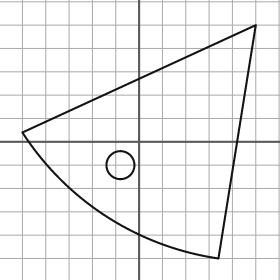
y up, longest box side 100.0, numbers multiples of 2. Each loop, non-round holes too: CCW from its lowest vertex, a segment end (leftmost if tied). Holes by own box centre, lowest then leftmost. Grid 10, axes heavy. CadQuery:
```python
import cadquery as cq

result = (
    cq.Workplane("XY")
    .moveTo(34.0, -50.0)
    .lineTo(50.0, 50.0)
    .lineTo(-50.0, 4.0)
    .threePointArc((-14.0, -32.0), (34.0, -50.0))
    .close()
    .moveTo(-8.0, -10.0)
    .circle(6.0)
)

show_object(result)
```